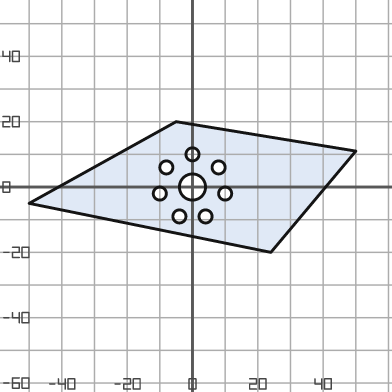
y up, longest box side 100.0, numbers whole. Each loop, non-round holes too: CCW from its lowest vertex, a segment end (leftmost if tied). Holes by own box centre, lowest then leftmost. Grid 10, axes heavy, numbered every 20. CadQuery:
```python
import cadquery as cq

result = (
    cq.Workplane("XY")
    .moveTo(24.0, -20.0)
    .lineTo(50.0, 11.0)
    .lineTo(-5.0, 20.0)
    .lineTo(-50.0, -5.0)
    .close()
    .moveTo(-4.0, -9.0)
    .circle(2.0)
    .moveTo(4.0, -9.0)
    .circle(2.0)
    .moveTo(-10.0, -2.0)
    .circle(2.0)
    .moveTo(10.0, -2.0)
    .circle(2.0)
    .moveTo(0.0, 0.0)
    .circle(4.0)
    .moveTo(-8.0, 6.0)
    .circle(2.0)
    .moveTo(8.0, 6.0)
    .circle(2.0)
    .moveTo(0.0, 10.0)
    .circle(2.0)
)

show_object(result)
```